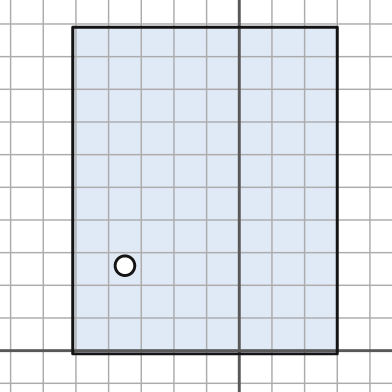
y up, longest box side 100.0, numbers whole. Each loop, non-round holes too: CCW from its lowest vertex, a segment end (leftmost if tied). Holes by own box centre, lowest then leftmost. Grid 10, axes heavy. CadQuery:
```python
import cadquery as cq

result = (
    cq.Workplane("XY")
    .moveTo(-51.0, -1.0)
    .lineTo(30.0, -1.0)
    .lineTo(30.0, 99.0)
    .lineTo(-51.0, 99.0)
    .close()
    .moveTo(-35.0, 26.0)
    .circle(3.0)
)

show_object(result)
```